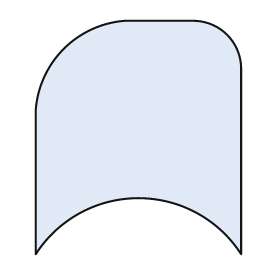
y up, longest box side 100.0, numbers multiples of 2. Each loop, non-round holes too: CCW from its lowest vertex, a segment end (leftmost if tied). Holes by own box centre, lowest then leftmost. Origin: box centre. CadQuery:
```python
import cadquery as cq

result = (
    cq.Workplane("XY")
    .moveTo(-44.0, -50.0)
    .threePointArc((0.0, -26.0), (44.0, -50.0))
    .lineTo(44.0, 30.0)
    .threePointArc((38.0, 44.0), (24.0, 50.0))
    .lineTo(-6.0, 50.0)
    .threePointArc((-32.0, 38.0), (-44.0, 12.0))
    .close()
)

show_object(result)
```